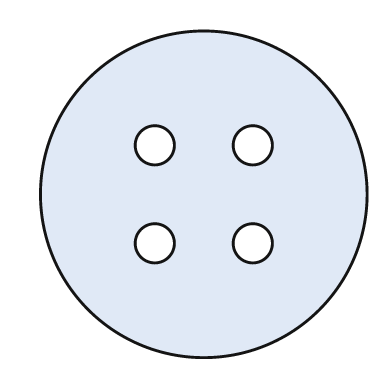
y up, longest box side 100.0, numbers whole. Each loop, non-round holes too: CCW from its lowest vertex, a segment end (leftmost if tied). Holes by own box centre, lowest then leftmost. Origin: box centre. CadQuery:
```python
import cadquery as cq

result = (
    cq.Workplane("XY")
    .moveTo(0.0, 0.0)
    .circle(50.0)
    .moveTo(-15.0, -15.0)
    .circle(6.0)
    .moveTo(15.0, -15.0)
    .circle(6.0)
    .moveTo(-15.0, 15.0)
    .circle(6.0)
    .moveTo(15.0, 15.0)
    .circle(6.0)
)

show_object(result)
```